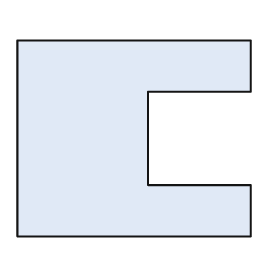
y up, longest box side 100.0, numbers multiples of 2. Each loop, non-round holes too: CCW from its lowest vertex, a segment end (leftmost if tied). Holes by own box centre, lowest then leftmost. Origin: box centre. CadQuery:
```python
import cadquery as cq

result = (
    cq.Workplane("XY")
    .moveTo(-50.0, -42.0)
    .lineTo(50.0, -42.0)
    .lineTo(50.0, -20.0)
    .lineTo(6.0, -20.0)
    .lineTo(6.0, 20.0)
    .lineTo(50.0, 20.0)
    .lineTo(50.0, 42.0)
    .lineTo(-50.0, 42.0)
    .close()
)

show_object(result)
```